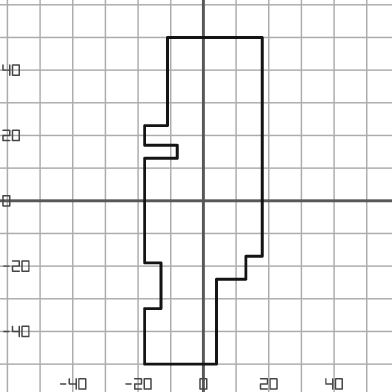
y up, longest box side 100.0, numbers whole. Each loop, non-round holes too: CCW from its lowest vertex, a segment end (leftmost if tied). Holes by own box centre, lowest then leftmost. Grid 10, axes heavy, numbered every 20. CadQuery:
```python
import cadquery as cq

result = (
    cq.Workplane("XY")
    .moveTo(-18.0, -50.0)
    .lineTo(4.0, -50.0)
    .lineTo(4.0, -24.0)
    .lineTo(13.0, -24.0)
    .lineTo(13.0, -17.0)
    .lineTo(18.0, -17.0)
    .lineTo(18.0, 50.0)
    .lineTo(-11.0, 50.0)
    .lineTo(-11.0, 23.0)
    .lineTo(-18.0, 23.0)
    .lineTo(-18.0, 17.0)
    .lineTo(-8.0, 17.0)
    .lineTo(-8.0, 13.0)
    .lineTo(-18.0, 13.0)
    .lineTo(-18.0, -19.0)
    .lineTo(-13.0, -19.0)
    .lineTo(-13.0, -33.0)
    .lineTo(-18.0, -33.0)
    .close()
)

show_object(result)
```